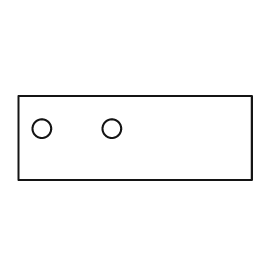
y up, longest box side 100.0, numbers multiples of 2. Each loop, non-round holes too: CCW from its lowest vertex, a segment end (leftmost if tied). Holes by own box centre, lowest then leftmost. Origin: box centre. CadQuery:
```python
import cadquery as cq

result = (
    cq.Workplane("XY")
    .moveTo(-50.0, -18.0)
    .lineTo(50.0, -18.0)
    .lineTo(50.0, 18.0)
    .lineTo(-50.0, 18.0)
    .close()
    .moveTo(-40.0, 4.0)
    .circle(4.0)
    .moveTo(-10.0, 4.0)
    .circle(4.0)
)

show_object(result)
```